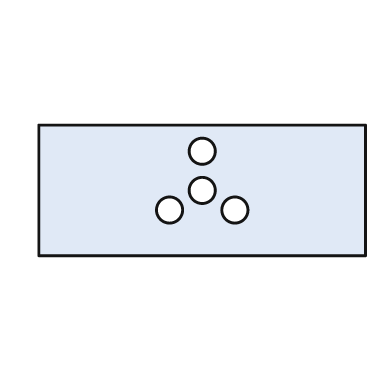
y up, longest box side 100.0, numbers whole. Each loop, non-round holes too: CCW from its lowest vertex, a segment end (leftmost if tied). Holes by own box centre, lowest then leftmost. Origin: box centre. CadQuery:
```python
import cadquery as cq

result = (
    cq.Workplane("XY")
    .moveTo(-50.0, -20.0)
    .lineTo(50.0, -20.0)
    .lineTo(50.0, 20.0)
    .lineTo(-50.0, 20.0)
    .close()
    .moveTo(-10.0, -6.0)
    .circle(4.0)
    .moveTo(10.0, -6.0)
    .circle(4.0)
    .moveTo(0.0, 0.0)
    .circle(4.0)
    .moveTo(0.0, 12.0)
    .circle(4.0)
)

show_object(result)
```